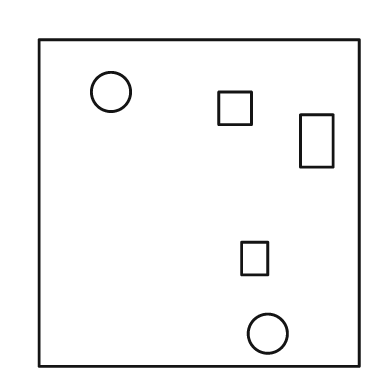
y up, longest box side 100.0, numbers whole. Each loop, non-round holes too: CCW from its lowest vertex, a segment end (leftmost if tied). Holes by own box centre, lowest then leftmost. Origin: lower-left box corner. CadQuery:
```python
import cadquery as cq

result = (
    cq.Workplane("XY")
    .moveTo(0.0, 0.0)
    .lineTo(98.0, 0.0)
    .lineTo(98.0, 100.0)
    .lineTo(0.0, 100.0)
    .close()
    .moveTo(70.0, 10.0)
    .circle(6.0)
    .moveTo(62.0, 28.0)
    .lineTo(70.0, 28.0)
    .lineTo(70.0, 38.0)
    .lineTo(62.0, 38.0)
    .close()
    .moveTo(80.0, 61.0)
    .lineTo(90.0, 61.0)
    .lineTo(90.0, 77.0)
    .lineTo(80.0, 77.0)
    .close()
    .moveTo(55.0, 74.0)
    .lineTo(65.0, 74.0)
    .lineTo(65.0, 84.0)
    .lineTo(55.0, 84.0)
    .close()
    .moveTo(22.0, 84.0)
    .circle(6.0)
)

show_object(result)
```